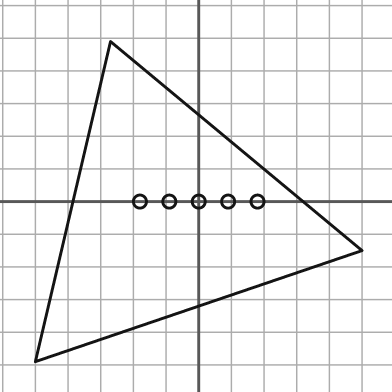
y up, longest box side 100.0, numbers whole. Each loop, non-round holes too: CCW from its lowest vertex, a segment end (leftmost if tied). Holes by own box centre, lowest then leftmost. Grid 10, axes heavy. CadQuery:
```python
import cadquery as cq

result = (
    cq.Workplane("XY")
    .moveTo(-50.0, -49.0)
    .lineTo(50.0, -15.0)
    .lineTo(-27.0, 49.0)
    .close()
    .moveTo(-18.0, 0.0)
    .circle(2.0)
    .moveTo(-9.0, 0.0)
    .circle(2.0)
    .moveTo(0.0, 0.0)
    .circle(2.0)
    .moveTo(9.0, 0.0)
    .circle(2.0)
    .moveTo(18.0, 0.0)
    .circle(2.0)
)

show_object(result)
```